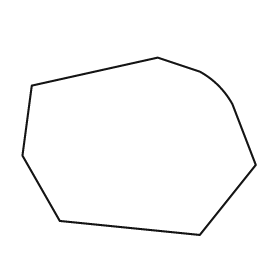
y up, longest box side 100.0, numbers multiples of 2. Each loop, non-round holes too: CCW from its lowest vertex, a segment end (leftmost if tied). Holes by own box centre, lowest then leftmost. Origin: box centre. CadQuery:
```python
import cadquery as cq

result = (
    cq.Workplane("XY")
    .moveTo(26.0, -38.0)
    .lineTo(50.0, -8.0)
    .lineTo(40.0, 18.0)
    .threePointArc((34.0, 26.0), (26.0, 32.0))
    .lineTo(8.0, 38.0)
    .lineTo(-46.0, 26.0)
    .lineTo(-50.0, -4.0)
    .lineTo(-34.0, -32.0)
    .close()
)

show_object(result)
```